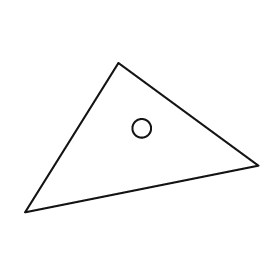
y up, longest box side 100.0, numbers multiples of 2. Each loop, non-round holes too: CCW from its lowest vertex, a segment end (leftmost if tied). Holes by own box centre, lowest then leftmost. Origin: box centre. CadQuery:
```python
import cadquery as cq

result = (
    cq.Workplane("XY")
    .moveTo(-50.0, -32.0)
    .lineTo(50.0, -12.0)
    .lineTo(-10.0, 32.0)
    .close()
    .moveTo(0.0, 4.0)
    .circle(4.0)
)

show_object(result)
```